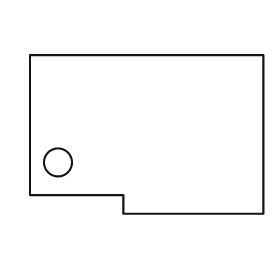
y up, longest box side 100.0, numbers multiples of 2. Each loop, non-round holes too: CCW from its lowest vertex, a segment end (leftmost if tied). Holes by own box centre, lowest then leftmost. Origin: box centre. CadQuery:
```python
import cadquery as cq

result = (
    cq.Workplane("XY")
    .moveTo(-10.0, -34.0)
    .lineTo(50.0, -34.0)
    .lineTo(50.0, 34.0)
    .lineTo(-50.0, 34.0)
    .lineTo(-50.0, -26.0)
    .lineTo(-10.0, -26.0)
    .close()
    .moveTo(-38.0, -12.0)
    .circle(6.0)
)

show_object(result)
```